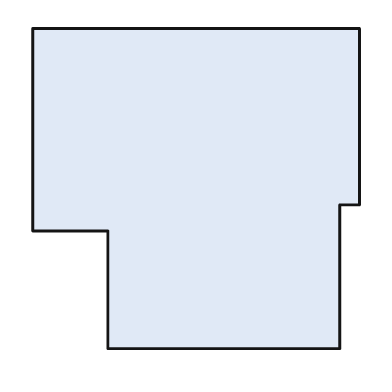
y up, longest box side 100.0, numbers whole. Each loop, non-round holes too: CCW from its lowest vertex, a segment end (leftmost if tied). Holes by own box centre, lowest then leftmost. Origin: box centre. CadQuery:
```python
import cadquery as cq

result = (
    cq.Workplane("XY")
    .moveTo(-27.0, -49.0)
    .lineTo(44.0, -49.0)
    .lineTo(44.0, -5.0)
    .lineTo(50.0, -5.0)
    .lineTo(50.0, 49.0)
    .lineTo(-50.0, 49.0)
    .lineTo(-50.0, -13.0)
    .lineTo(-27.0, -13.0)
    .close()
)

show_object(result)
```